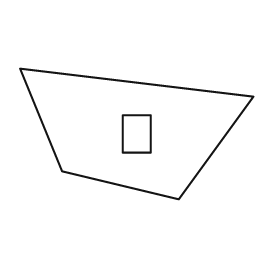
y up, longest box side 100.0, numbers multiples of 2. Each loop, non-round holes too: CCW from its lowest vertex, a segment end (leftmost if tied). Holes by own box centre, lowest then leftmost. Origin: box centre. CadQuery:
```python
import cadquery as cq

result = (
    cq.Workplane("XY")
    .moveTo(18.0, -28.0)
    .lineTo(50.0, 16.0)
    .lineTo(-50.0, 28.0)
    .lineTo(-32.0, -16.0)
    .close()
    .moveTo(-6.0, -8.0)
    .lineTo(6.0, -8.0)
    .lineTo(6.0, 8.0)
    .lineTo(-6.0, 8.0)
    .close()
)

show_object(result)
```